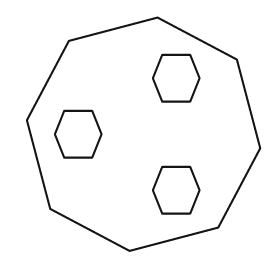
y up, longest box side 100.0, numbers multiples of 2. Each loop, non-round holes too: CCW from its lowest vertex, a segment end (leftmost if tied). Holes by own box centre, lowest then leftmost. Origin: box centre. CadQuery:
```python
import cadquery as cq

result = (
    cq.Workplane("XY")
    .moveTo(-6.0, -50.0)
    .lineTo(32.0, -40.0)
    .lineTo(50.0, -6.0)
    .lineTo(40.0, 32.0)
    .lineTo(6.0, 50.0)
    .lineTo(-32.0, 40.0)
    .lineTo(-50.0, 6.0)
    .lineTo(-40.0, -32.0)
    .close()
    .moveTo(8.0, -34.0)
    .lineTo(20.0, -34.0)
    .lineTo(24.0, -24.0)
    .lineTo(20.0, -14.0)
    .lineTo(8.0, -14.0)
    .lineTo(4.0, -24.0)
    .close()
    .moveTo(-34.0, -10.0)
    .lineTo(-22.0, -10.0)
    .lineTo(-18.0, 0.0)
    .lineTo(-22.0, 10.0)
    .lineTo(-34.0, 10.0)
    .lineTo(-38.0, 0.0)
    .close()
    .moveTo(8.0, 14.0)
    .lineTo(20.0, 14.0)
    .lineTo(24.0, 24.0)
    .lineTo(20.0, 34.0)
    .lineTo(8.0, 34.0)
    .lineTo(4.0, 24.0)
    .close()
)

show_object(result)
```